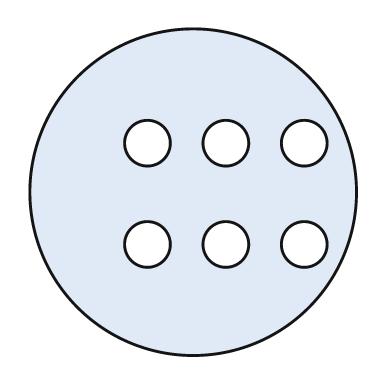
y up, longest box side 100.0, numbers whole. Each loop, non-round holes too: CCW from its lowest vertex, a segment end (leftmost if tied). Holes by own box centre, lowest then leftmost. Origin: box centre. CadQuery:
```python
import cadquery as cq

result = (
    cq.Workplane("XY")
    .moveTo(0.0, 0.0)
    .circle(50.0)
    .moveTo(-14.0, -16.0)
    .circle(7.0)
    .moveTo(10.0, -16.0)
    .circle(7.0)
    .moveTo(34.0, -16.0)
    .circle(7.0)
    .moveTo(-14.0, 15.0)
    .circle(7.0)
    .moveTo(10.0, 15.0)
    .circle(7.0)
    .moveTo(34.0, 15.0)
    .circle(7.0)
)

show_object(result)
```